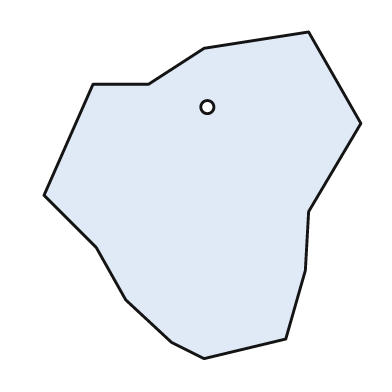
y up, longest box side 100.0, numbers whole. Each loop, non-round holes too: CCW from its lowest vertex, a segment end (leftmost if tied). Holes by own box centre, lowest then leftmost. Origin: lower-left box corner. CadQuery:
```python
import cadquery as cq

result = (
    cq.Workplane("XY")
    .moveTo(49.0, 0.0)
    .lineTo(74.0, 6.0)
    .lineTo(80.0, 27.0)
    .lineTo(81.0, 45.0)
    .lineTo(97.0, 72.0)
    .lineTo(81.0, 100.0)
    .lineTo(49.0, 95.0)
    .lineTo(32.0, 84.0)
    .lineTo(15.0, 84.0)
    .lineTo(0.0, 50.0)
    .lineTo(16.0, 34.0)
    .lineTo(25.0, 18.0)
    .lineTo(39.0, 5.0)
    .close()
    .moveTo(50.0, 77.0)
    .circle(2.0)
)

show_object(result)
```